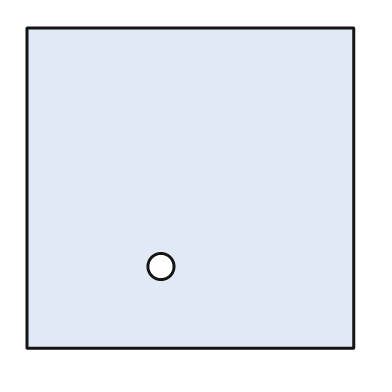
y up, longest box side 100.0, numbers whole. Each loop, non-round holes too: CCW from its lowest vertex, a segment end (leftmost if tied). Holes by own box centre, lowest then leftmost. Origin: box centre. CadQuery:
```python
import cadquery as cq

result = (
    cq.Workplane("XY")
    .moveTo(-50.0, -49.0)
    .lineTo(50.0, -49.0)
    .lineTo(50.0, 49.0)
    .lineTo(-50.0, 49.0)
    .close()
    .moveTo(-9.0, -24.0)
    .circle(4.0)
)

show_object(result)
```